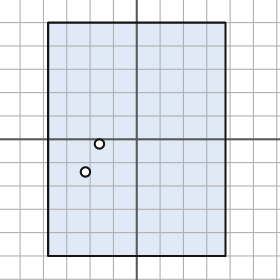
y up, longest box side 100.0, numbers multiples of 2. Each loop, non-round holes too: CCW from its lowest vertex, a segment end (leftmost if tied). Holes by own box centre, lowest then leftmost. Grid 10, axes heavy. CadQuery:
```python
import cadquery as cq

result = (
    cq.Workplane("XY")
    .moveTo(-38.0, -50.0)
    .lineTo(38.0, -50.0)
    .lineTo(38.0, 50.0)
    .lineTo(-38.0, 50.0)
    .close()
    .moveTo(-22.0, -14.0)
    .circle(2.0)
    .moveTo(-16.0, -2.0)
    .circle(2.0)
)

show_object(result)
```